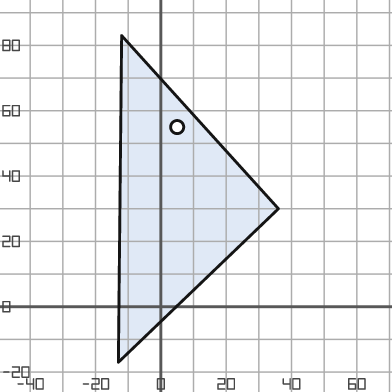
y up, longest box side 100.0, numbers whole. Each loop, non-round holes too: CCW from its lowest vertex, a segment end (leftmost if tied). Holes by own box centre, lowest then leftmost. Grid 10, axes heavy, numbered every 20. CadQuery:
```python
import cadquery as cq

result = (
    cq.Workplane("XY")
    .moveTo(-13.0, -17.0)
    .lineTo(36.0, 30.0)
    .lineTo(-12.0, 83.0)
    .close()
    .moveTo(5.0, 55.0)
    .circle(2.0)
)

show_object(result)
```